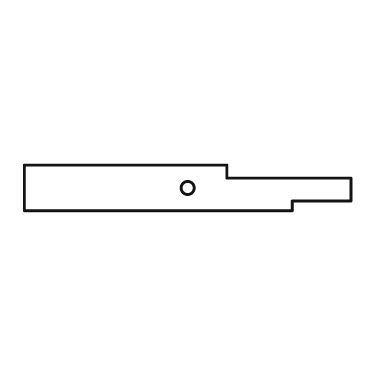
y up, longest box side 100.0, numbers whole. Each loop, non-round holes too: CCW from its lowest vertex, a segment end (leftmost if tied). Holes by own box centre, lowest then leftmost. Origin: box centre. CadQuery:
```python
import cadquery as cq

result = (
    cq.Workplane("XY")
    .moveTo(-50.0, -7.0)
    .lineTo(32.0, -7.0)
    .lineTo(32.0, -4.0)
    .lineTo(50.0, -4.0)
    .lineTo(50.0, 3.0)
    .lineTo(12.0, 3.0)
    .lineTo(12.0, 7.0)
    .lineTo(-50.0, 7.0)
    .close()
    .moveTo(0.0, 0.0)
    .circle(2.0)
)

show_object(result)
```